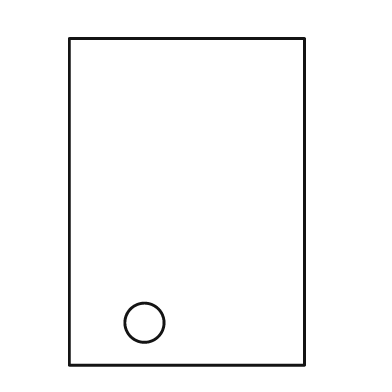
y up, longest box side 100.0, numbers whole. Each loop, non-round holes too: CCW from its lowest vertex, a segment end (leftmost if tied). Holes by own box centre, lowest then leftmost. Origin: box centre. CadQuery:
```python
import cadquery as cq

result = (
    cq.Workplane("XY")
    .moveTo(-36.0, -50.0)
    .lineTo(36.0, -50.0)
    .lineTo(36.0, 50.0)
    .lineTo(-36.0, 50.0)
    .close()
    .moveTo(-13.0, -37.0)
    .circle(6.0)
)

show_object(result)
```